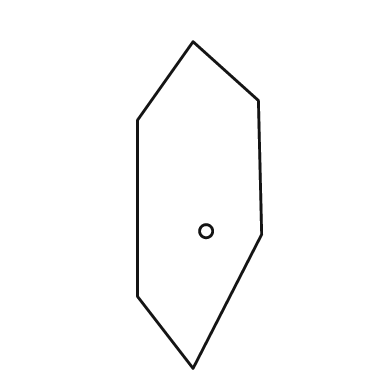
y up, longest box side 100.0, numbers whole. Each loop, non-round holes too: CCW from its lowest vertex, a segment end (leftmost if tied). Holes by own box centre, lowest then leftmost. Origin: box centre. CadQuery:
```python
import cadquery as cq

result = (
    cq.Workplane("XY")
    .moveTo(-2.0, -50.0)
    .lineTo(19.0, -9.0)
    .lineTo(18.0, 32.0)
    .lineTo(-2.0, 50.0)
    .lineTo(-19.0, 26.0)
    .lineTo(-19.0, -28.0)
    .close()
    .moveTo(2.0, -8.0)
    .circle(2.0)
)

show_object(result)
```